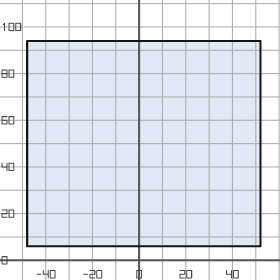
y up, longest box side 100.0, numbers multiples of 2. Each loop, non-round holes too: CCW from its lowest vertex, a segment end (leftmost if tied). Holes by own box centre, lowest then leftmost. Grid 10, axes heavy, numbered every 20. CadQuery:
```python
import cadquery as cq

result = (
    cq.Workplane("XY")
    .moveTo(-48.0, 6.0)
    .lineTo(52.0, 6.0)
    .lineTo(52.0, 94.0)
    .lineTo(-48.0, 94.0)
    .close()
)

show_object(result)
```